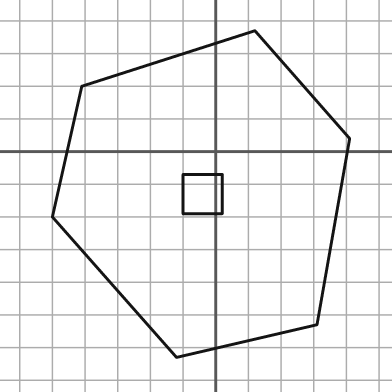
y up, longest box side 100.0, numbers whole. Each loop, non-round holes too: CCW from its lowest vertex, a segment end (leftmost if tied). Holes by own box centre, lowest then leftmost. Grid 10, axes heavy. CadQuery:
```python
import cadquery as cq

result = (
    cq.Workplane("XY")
    .moveTo(-12.0, -63.0)
    .lineTo(31.0, -53.0)
    .lineTo(41.0, 4.0)
    .lineTo(12.0, 37.0)
    .lineTo(-41.0, 20.0)
    .lineTo(-50.0, -20.0)
    .close()
    .moveTo(-10.0, -19.0)
    .lineTo(2.0, -19.0)
    .lineTo(2.0, -7.0)
    .lineTo(-10.0, -7.0)
    .close()
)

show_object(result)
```